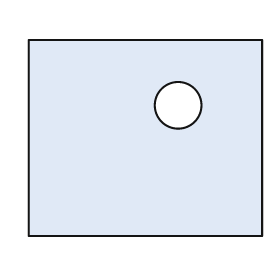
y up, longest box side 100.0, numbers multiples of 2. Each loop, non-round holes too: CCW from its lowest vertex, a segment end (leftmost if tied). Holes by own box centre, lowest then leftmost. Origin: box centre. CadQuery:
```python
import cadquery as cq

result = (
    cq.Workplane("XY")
    .moveTo(-50.0, -42.0)
    .lineTo(50.0, -42.0)
    .lineTo(50.0, 42.0)
    .lineTo(-50.0, 42.0)
    .close()
    .moveTo(14.0, 14.0)
    .circle(10.0)
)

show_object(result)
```